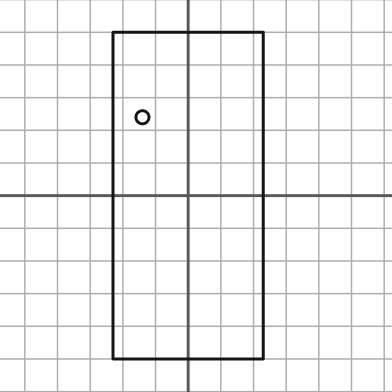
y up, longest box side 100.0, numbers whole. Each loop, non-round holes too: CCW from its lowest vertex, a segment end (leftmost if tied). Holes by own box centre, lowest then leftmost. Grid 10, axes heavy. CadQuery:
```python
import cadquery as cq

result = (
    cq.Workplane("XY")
    .moveTo(-23.0, -50.0)
    .lineTo(23.0, -50.0)
    .lineTo(23.0, 50.0)
    .lineTo(-23.0, 50.0)
    .close()
    .moveTo(-14.0, 24.0)
    .circle(2.0)
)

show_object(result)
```